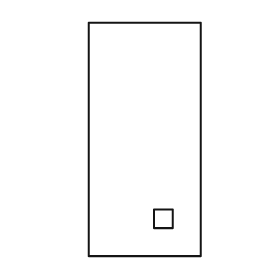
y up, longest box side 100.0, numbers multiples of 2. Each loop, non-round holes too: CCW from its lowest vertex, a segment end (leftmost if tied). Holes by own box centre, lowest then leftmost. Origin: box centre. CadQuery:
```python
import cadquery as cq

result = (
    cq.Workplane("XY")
    .moveTo(-24.0, -50.0)
    .lineTo(24.0, -50.0)
    .lineTo(24.0, 50.0)
    .lineTo(-24.0, 50.0)
    .close()
    .moveTo(4.0, -38.0)
    .lineTo(12.0, -38.0)
    .lineTo(12.0, -30.0)
    .lineTo(4.0, -30.0)
    .close()
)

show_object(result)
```